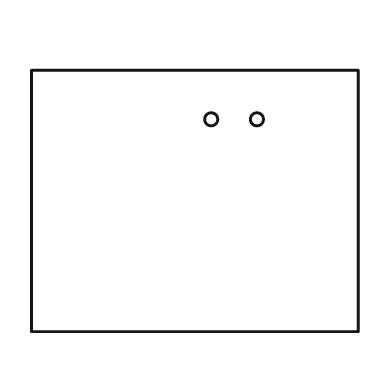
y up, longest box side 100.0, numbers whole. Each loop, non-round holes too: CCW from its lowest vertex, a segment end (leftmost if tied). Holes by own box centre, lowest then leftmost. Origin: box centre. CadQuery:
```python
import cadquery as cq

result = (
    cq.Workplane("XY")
    .moveTo(-50.0, -40.0)
    .lineTo(50.0, -40.0)
    .lineTo(50.0, 40.0)
    .lineTo(-50.0, 40.0)
    .close()
    .moveTo(5.0, 25.0)
    .circle(2.0)
    .moveTo(19.0, 25.0)
    .circle(2.0)
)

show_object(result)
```